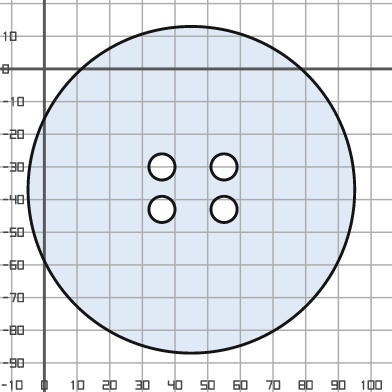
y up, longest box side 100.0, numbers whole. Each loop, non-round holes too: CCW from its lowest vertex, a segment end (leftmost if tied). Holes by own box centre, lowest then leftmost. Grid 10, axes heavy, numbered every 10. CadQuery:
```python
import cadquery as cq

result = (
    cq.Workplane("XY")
    .moveTo(45.0, -37.0)
    .circle(50.0)
    .moveTo(36.0, -43.0)
    .circle(4.0)
    .moveTo(55.0, -43.0)
    .circle(4.0)
    .moveTo(36.0, -30.0)
    .circle(4.0)
    .moveTo(55.0, -30.0)
    .circle(4.0)
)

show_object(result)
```